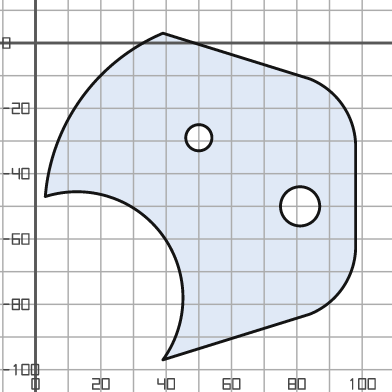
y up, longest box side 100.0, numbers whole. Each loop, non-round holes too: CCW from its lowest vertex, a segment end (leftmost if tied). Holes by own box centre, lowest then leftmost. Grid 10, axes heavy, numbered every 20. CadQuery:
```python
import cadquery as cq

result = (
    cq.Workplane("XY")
    .moveTo(39.0, -97.0)
    .lineTo(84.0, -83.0)
    .threePointArc((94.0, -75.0), (98.0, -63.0))
    .lineTo(98.0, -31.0)
    .threePointArc((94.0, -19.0), (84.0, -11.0))
    .lineTo(39.0, 3.0)
    .threePointArc((14.0, -17.0), (3.0, -47.0))
    .threePointArc((39.0, -59.0), (39.0, -97.0))
    .close()
    .moveTo(81.0, -50.0)
    .circle(6.0)
    .moveTo(50.0, -29.0)
    .circle(4.0)
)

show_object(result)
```